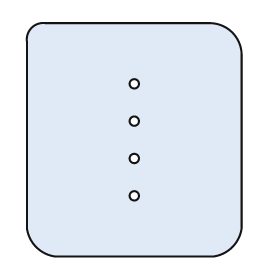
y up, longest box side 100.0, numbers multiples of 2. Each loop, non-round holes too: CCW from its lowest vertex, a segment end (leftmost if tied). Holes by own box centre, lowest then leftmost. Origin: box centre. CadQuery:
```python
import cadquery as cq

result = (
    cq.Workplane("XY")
    .moveTo(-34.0, -50.0)
    .lineTo(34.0, -50.0)
    .threePointArc((42.0, -46.0), (46.0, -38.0))
    .lineTo(46.0, 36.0)
    .threePointArc((42.0, 46.0), (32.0, 50.0))
    .lineTo(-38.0, 50.0)
    .threePointArc((-44.0, 48.0), (-46.0, 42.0))
    .lineTo(-46.0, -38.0)
    .threePointArc((-42.0, -46.0), (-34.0, -50.0))
    .close()
    .moveTo(0.0, -24.0)
    .circle(2.0)
    .moveTo(0.0, -8.0)
    .circle(2.0)
    .moveTo(0.0, 8.0)
    .circle(2.0)
    .moveTo(0.0, 24.0)
    .circle(2.0)
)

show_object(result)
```